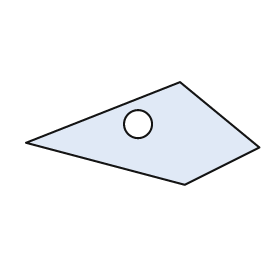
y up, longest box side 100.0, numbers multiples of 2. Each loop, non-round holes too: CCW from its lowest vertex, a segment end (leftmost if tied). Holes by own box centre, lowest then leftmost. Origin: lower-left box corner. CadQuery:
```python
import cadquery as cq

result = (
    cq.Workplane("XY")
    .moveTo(68.0, 0.0)
    .lineTo(100.0, 16.0)
    .lineTo(66.0, 44.0)
    .lineTo(0.0, 18.0)
    .close()
    .moveTo(48.0, 26.0)
    .circle(6.0)
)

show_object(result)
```